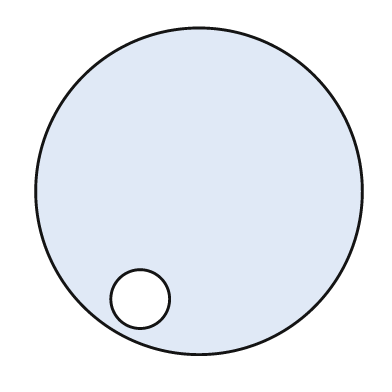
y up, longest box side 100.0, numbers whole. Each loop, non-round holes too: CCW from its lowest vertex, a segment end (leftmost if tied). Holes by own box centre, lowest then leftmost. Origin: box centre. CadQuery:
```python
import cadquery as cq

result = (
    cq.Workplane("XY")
    .moveTo(0.0, 0.0)
    .circle(50.0)
    .moveTo(-18.0, -33.0)
    .circle(9.0)
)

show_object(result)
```